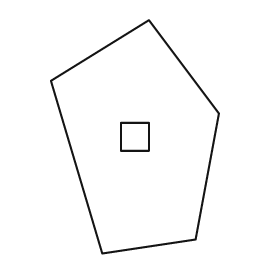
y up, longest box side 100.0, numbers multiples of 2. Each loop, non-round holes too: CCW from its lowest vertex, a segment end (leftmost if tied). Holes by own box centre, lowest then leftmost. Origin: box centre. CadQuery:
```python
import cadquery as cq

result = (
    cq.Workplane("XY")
    .moveTo(-14.0, -50.0)
    .lineTo(26.0, -44.0)
    .lineTo(36.0, 10.0)
    .lineTo(6.0, 50.0)
    .lineTo(-36.0, 24.0)
    .close()
    .moveTo(-6.0, -6.0)
    .lineTo(6.0, -6.0)
    .lineTo(6.0, 6.0)
    .lineTo(-6.0, 6.0)
    .close()
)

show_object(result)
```